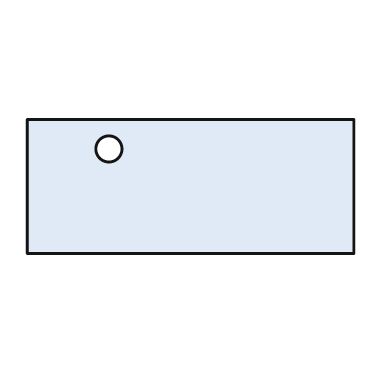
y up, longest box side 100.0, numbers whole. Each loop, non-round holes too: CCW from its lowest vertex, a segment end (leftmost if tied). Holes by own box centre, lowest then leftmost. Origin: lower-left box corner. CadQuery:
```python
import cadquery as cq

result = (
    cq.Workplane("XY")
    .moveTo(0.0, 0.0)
    .lineTo(100.0, 0.0)
    .lineTo(100.0, 41.0)
    .lineTo(0.0, 41.0)
    .close()
    .moveTo(25.0, 32.0)
    .circle(4.0)
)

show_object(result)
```